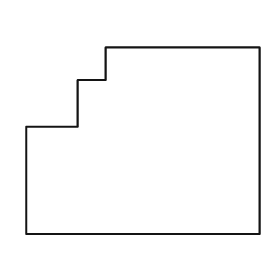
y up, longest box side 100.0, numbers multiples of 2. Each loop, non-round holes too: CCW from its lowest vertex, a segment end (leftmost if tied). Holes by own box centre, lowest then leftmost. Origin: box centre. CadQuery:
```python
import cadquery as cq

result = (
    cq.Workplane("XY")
    .moveTo(-50.0, -40.0)
    .lineTo(50.0, -40.0)
    .lineTo(50.0, 40.0)
    .lineTo(-16.0, 40.0)
    .lineTo(-16.0, 26.0)
    .lineTo(-28.0, 26.0)
    .lineTo(-28.0, 6.0)
    .lineTo(-50.0, 6.0)
    .close()
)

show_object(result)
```